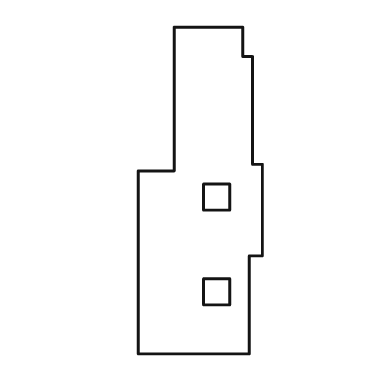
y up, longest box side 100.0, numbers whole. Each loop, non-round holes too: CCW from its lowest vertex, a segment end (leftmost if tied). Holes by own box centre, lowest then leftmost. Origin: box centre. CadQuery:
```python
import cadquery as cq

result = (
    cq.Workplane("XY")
    .moveTo(-19.0, -50.0)
    .lineTo(15.0, -50.0)
    .lineTo(15.0, -20.0)
    .lineTo(19.0, -20.0)
    .lineTo(19.0, 8.0)
    .lineTo(16.0, 8.0)
    .lineTo(16.0, 41.0)
    .lineTo(13.0, 41.0)
    .lineTo(13.0, 50.0)
    .lineTo(-8.0, 50.0)
    .lineTo(-8.0, 6.0)
    .lineTo(-19.0, 6.0)
    .close()
    .moveTo(1.0, -35.0)
    .lineTo(9.0, -35.0)
    .lineTo(9.0, -27.0)
    .lineTo(1.0, -27.0)
    .close()
    .moveTo(1.0, -6.0)
    .lineTo(9.0, -6.0)
    .lineTo(9.0, 2.0)
    .lineTo(1.0, 2.0)
    .close()
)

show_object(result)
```